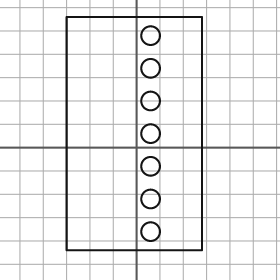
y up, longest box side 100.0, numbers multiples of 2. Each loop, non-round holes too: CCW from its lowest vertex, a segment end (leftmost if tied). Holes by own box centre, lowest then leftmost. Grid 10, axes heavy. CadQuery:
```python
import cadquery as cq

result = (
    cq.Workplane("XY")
    .moveTo(-30.0, -44.0)
    .lineTo(28.0, -44.0)
    .lineTo(28.0, 56.0)
    .lineTo(-30.0, 56.0)
    .close()
    .moveTo(6.0, -36.0)
    .circle(4.0)
    .moveTo(6.0, -22.0)
    .circle(4.0)
    .moveTo(6.0, -8.0)
    .circle(4.0)
    .moveTo(6.0, 6.0)
    .circle(4.0)
    .moveTo(6.0, 20.0)
    .circle(4.0)
    .moveTo(6.0, 34.0)
    .circle(4.0)
    .moveTo(6.0, 48.0)
    .circle(4.0)
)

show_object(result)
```